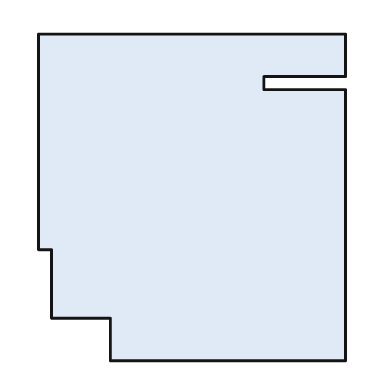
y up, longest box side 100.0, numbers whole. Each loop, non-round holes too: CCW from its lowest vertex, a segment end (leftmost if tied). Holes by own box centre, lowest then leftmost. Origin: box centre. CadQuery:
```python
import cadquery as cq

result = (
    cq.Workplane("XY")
    .moveTo(-25.0, -50.0)
    .lineTo(47.0, -50.0)
    .lineTo(47.0, 33.0)
    .lineTo(22.0, 33.0)
    .lineTo(22.0, 37.0)
    .lineTo(47.0, 37.0)
    .lineTo(47.0, 50.0)
    .lineTo(-47.0, 50.0)
    .lineTo(-47.0, -16.0)
    .lineTo(-43.0, -16.0)
    .lineTo(-43.0, -37.0)
    .lineTo(-25.0, -37.0)
    .close()
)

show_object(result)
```